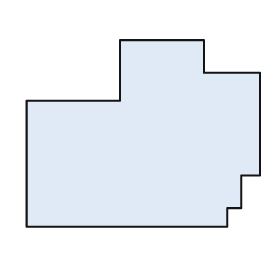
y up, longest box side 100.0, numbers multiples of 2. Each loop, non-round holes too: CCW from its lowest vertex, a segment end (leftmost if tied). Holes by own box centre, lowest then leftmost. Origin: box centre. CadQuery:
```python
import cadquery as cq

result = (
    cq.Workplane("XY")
    .moveTo(-50.0, -40.0)
    .lineTo(36.0, -40.0)
    .lineTo(36.0, -32.0)
    .lineTo(42.0, -32.0)
    .lineTo(42.0, -18.0)
    .lineTo(50.0, -18.0)
    .lineTo(50.0, 26.0)
    .lineTo(26.0, 26.0)
    .lineTo(26.0, 40.0)
    .lineTo(-10.0, 40.0)
    .lineTo(-10.0, 14.0)
    .lineTo(-50.0, 14.0)
    .close()
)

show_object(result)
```